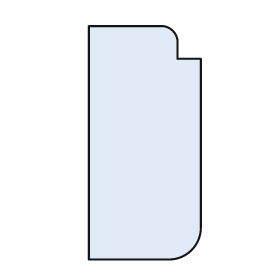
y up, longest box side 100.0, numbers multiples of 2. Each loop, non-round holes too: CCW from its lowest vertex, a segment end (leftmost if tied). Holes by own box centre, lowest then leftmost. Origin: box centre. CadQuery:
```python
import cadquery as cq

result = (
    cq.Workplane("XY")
    .moveTo(-24.0, -50.0)
    .lineTo(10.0, -50.0)
    .threePointArc((20.0, -46.0), (24.0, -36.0))
    .lineTo(24.0, 36.0)
    .lineTo(14.0, 36.0)
    .lineTo(14.0, 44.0)
    .threePointArc((12.0, 48.0), (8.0, 50.0))
    .lineTo(-24.0, 50.0)
    .close()
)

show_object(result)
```